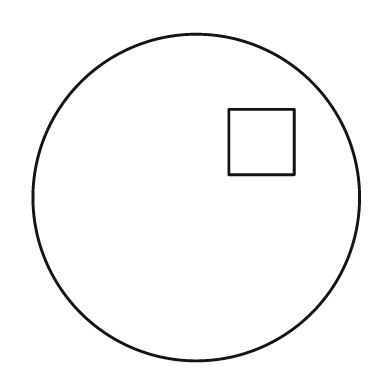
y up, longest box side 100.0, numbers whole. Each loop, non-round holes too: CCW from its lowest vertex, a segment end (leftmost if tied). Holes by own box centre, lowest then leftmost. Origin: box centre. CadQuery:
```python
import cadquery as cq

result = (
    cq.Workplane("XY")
    .moveTo(0.0, 0.0)
    .circle(50.0)
    .moveTo(10.0, 7.0)
    .lineTo(30.0, 7.0)
    .lineTo(30.0, 27.0)
    .lineTo(10.0, 27.0)
    .close()
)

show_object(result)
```